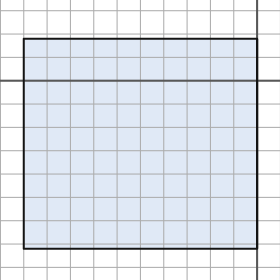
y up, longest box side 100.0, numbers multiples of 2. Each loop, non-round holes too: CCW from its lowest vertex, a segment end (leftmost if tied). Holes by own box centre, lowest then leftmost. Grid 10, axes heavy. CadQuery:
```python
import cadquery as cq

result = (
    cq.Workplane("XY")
    .moveTo(-100.0, -72.0)
    .lineTo(0.0, -72.0)
    .lineTo(0.0, 18.0)
    .lineTo(-100.0, 18.0)
    .close()
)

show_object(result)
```